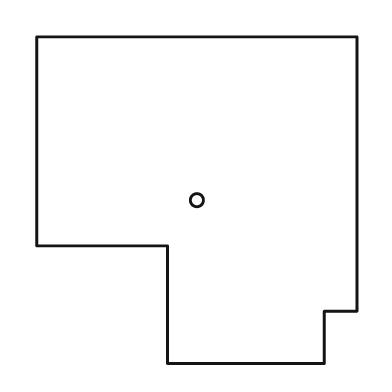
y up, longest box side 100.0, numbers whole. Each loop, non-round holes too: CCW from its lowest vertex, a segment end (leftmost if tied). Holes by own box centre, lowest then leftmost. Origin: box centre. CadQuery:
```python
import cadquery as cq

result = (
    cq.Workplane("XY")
    .moveTo(-9.0, -50.0)
    .lineTo(39.0, -50.0)
    .lineTo(39.0, -34.0)
    .lineTo(49.0, -34.0)
    .lineTo(49.0, 50.0)
    .lineTo(-49.0, 50.0)
    .lineTo(-49.0, -14.0)
    .lineTo(-9.0, -14.0)
    .close()
    .moveTo(0.0, 0.0)
    .circle(2.0)
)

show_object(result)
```